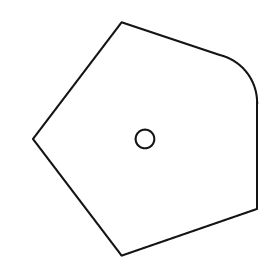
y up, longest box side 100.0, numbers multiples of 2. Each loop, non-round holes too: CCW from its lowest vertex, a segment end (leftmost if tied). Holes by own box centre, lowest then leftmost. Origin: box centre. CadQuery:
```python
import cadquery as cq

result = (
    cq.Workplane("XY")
    .moveTo(-10.0, -50.0)
    .lineTo(48.0, -30.0)
    .lineTo(48.0, 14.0)
    .threePointArc((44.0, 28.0), (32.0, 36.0))
    .lineTo(-10.0, 50.0)
    .lineTo(-48.0, 0.0)
    .close()
    .moveTo(0.0, 0.0)
    .circle(4.0)
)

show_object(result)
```